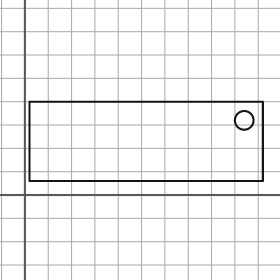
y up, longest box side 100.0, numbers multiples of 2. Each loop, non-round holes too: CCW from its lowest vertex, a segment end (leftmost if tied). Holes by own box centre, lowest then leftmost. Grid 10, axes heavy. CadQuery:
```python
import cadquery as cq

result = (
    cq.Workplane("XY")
    .moveTo(2.0, 6.0)
    .lineTo(102.0, 6.0)
    .lineTo(102.0, 40.0)
    .lineTo(2.0, 40.0)
    .close()
    .moveTo(94.0, 32.0)
    .circle(4.0)
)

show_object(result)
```